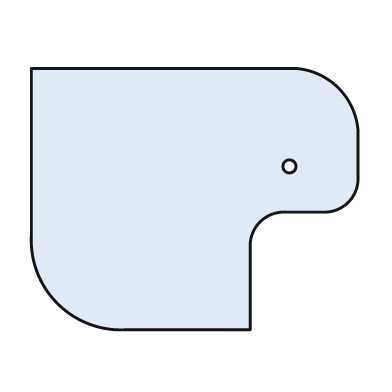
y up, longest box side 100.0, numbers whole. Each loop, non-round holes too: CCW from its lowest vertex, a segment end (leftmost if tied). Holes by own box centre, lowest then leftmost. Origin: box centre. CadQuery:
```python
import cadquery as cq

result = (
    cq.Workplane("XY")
    .moveTo(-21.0, -40.0)
    .lineTo(17.0, -40.0)
    .lineTo(17.0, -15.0)
    .threePointArc((20.0, -7.0), (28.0, -4.0))
    .lineTo(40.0, -4.0)
    .threePointArc((47.0, -1.0), (50.0, 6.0))
    .lineTo(50.0, 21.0)
    .threePointArc((44.0, 34.0), (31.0, 40.0))
    .lineTo(-50.0, 40.0)
    .lineTo(-50.0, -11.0)
    .threePointArc((-42.0, -32.0), (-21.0, -40.0))
    .close()
    .moveTo(29.0, 10.0)
    .circle(2.0)
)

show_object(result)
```